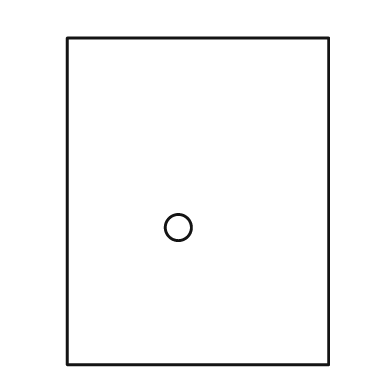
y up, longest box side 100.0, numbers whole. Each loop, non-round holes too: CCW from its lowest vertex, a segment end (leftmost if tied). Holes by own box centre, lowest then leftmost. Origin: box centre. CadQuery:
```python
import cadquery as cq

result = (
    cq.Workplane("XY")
    .moveTo(-40.0, -50.0)
    .lineTo(40.0, -50.0)
    .lineTo(40.0, 50.0)
    .lineTo(-40.0, 50.0)
    .close()
    .moveTo(-6.0, -8.0)
    .circle(4.0)
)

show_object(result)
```